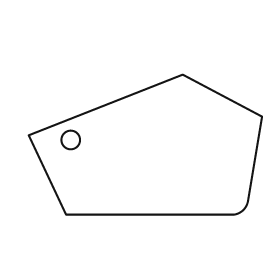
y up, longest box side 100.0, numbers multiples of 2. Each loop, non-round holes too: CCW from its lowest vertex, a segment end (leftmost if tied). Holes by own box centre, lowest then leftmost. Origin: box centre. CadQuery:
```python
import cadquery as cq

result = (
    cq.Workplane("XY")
    .moveTo(-34.0, -30.0)
    .lineTo(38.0, -30.0)
    .threePointArc((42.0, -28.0), (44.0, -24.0))
    .lineTo(50.0, 12.0)
    .lineTo(16.0, 30.0)
    .lineTo(-50.0, 4.0)
    .close()
    .moveTo(-32.0, 2.0)
    .circle(4.0)
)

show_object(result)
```